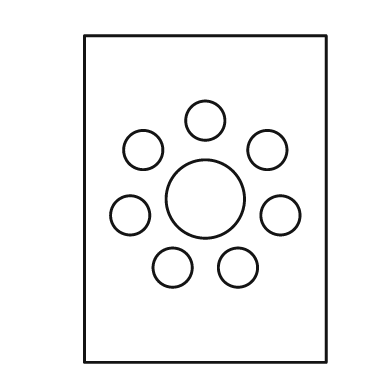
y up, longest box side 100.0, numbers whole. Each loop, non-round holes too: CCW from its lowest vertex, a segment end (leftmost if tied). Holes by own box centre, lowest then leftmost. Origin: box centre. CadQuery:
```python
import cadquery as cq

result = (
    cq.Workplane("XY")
    .moveTo(-37.0, -50.0)
    .lineTo(37.0, -50.0)
    .lineTo(37.0, 50.0)
    .lineTo(-37.0, 50.0)
    .close()
    .moveTo(-10.0, -21.0)
    .circle(6.0)
    .moveTo(10.0, -21.0)
    .circle(6.0)
    .moveTo(-23.0, -5.0)
    .circle(6.0)
    .moveTo(23.0, -5.0)
    .circle(6.0)
    .moveTo(0.0, 0.0)
    .circle(12.0)
    .moveTo(-19.0, 15.0)
    .circle(6.0)
    .moveTo(19.0, 15.0)
    .circle(6.0)
    .moveTo(0.0, 24.0)
    .circle(6.0)
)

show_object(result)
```